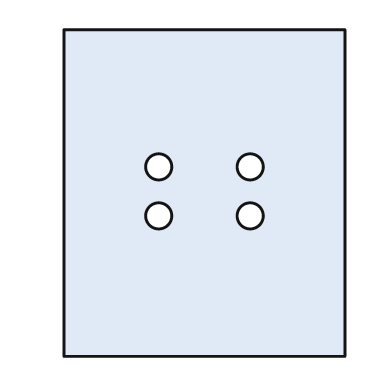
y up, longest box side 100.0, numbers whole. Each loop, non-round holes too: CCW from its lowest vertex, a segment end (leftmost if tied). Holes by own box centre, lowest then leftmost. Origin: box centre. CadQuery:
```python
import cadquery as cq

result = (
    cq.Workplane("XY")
    .moveTo(-43.0, -50.0)
    .lineTo(43.0, -50.0)
    .lineTo(43.0, 50.0)
    .lineTo(-43.0, 50.0)
    .close()
    .moveTo(-14.0, -7.0)
    .circle(4.0)
    .moveTo(14.0, -7.0)
    .circle(4.0)
    .moveTo(-14.0, 8.0)
    .circle(4.0)
    .moveTo(14.0, 8.0)
    .circle(4.0)
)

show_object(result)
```